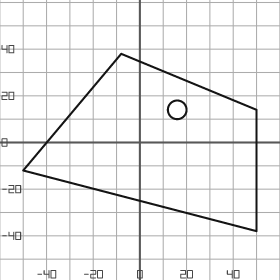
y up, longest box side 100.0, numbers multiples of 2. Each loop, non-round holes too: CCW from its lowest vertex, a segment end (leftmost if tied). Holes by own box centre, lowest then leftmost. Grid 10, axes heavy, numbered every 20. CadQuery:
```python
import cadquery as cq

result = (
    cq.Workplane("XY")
    .moveTo(50.0, -38.0)
    .lineTo(50.0, 14.0)
    .lineTo(-8.0, 38.0)
    .lineTo(-50.0, -12.0)
    .close()
    .moveTo(16.0, 14.0)
    .circle(4.0)
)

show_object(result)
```